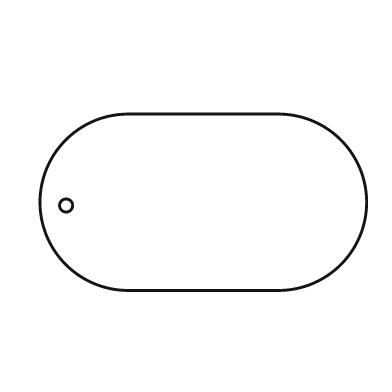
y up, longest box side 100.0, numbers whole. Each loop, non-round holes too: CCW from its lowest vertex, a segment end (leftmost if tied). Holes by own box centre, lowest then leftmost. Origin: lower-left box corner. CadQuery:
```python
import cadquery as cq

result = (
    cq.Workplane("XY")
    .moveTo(27.0, 0.0)
    .lineTo(73.0, 0.0)
    .threePointArc((100.0, 27.0), (73.0, 54.0))
    .lineTo(27.0, 54.0)
    .threePointArc((0.0, 27.0), (27.0, 0.0))
    .close()
    .moveTo(8.0, 26.0)
    .circle(2.0)
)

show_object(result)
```